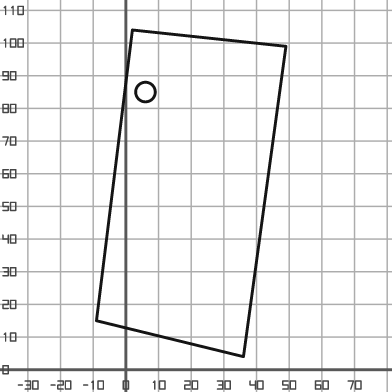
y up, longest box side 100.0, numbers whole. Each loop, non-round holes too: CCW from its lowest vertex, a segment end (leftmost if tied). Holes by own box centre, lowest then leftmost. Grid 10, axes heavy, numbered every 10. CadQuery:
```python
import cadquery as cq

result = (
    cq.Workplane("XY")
    .moveTo(36.0, 4.0)
    .lineTo(49.0, 99.0)
    .lineTo(2.0, 104.0)
    .lineTo(-9.0, 15.0)
    .close()
    .moveTo(6.0, 85.0)
    .circle(3.0)
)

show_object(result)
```